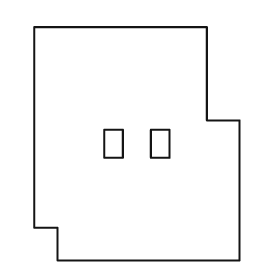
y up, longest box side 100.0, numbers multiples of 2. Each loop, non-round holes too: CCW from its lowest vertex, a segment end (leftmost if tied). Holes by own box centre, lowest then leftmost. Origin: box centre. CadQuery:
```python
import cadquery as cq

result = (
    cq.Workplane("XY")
    .moveTo(-34.0, -50.0)
    .lineTo(44.0, -50.0)
    .lineTo(44.0, 10.0)
    .lineTo(30.0, 10.0)
    .lineTo(30.0, 50.0)
    .lineTo(-44.0, 50.0)
    .lineTo(-44.0, -36.0)
    .lineTo(-34.0, -36.0)
    .close()
    .moveTo(-14.0, -6.0)
    .lineTo(-6.0, -6.0)
    .lineTo(-6.0, 6.0)
    .lineTo(-14.0, 6.0)
    .close()
    .moveTo(6.0, -6.0)
    .lineTo(14.0, -6.0)
    .lineTo(14.0, 6.0)
    .lineTo(6.0, 6.0)
    .close()
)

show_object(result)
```